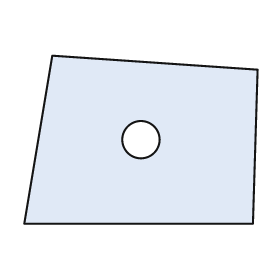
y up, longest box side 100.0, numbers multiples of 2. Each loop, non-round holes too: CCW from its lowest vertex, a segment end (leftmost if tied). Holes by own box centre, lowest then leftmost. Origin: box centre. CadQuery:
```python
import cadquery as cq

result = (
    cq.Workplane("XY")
    .moveTo(-50.0, -36.0)
    .lineTo(48.0, -36.0)
    .lineTo(50.0, 30.0)
    .lineTo(-38.0, 36.0)
    .close()
    .moveTo(0.0, 0.0)
    .circle(8.0)
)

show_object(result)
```